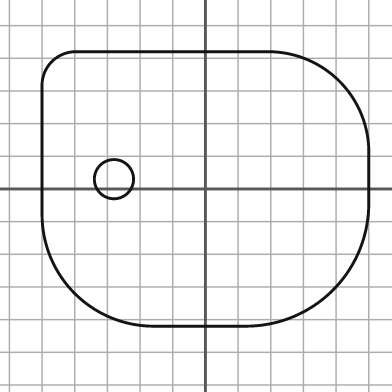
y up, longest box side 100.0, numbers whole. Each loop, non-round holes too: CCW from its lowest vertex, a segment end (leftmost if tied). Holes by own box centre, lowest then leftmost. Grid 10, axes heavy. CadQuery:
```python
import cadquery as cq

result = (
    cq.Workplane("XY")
    .moveTo(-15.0, -42.0)
    .lineTo(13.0, -42.0)
    .threePointArc((39.0, -31.0), (50.0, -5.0))
    .lineTo(50.0, 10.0)
    .threePointArc((41.0, 33.0), (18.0, 42.0))
    .lineTo(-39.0, 42.0)
    .threePointArc((-47.0, 39.0), (-50.0, 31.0))
    .lineTo(-50.0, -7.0)
    .threePointArc((-40.0, -32.0), (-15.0, -42.0))
    .close()
    .moveTo(-28.0, 3.0)
    .circle(6.0)
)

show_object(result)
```